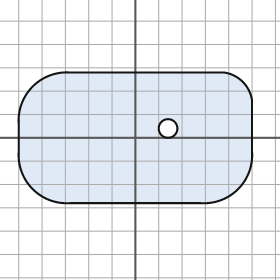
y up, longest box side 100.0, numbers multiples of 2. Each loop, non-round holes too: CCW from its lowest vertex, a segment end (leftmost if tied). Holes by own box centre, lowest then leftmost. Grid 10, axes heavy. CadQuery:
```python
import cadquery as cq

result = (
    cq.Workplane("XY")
    .moveTo(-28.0, -28.0)
    .lineTo(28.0, -28.0)
    .threePointArc((44.0, -22.0), (50.0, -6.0))
    .lineTo(50.0, 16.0)
    .threePointArc((46.0, 24.0), (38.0, 28.0))
    .lineTo(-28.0, 28.0)
    .threePointArc((-44.0, 22.0), (-50.0, 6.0))
    .lineTo(-50.0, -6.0)
    .threePointArc((-44.0, -22.0), (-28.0, -28.0))
    .close()
    .moveTo(14.0, 4.0)
    .circle(4.0)
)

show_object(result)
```